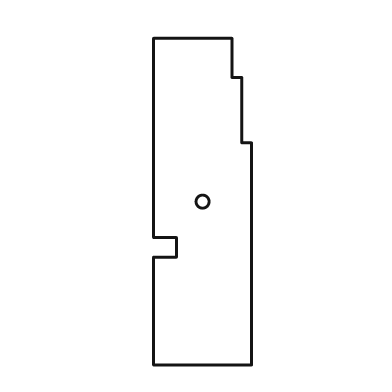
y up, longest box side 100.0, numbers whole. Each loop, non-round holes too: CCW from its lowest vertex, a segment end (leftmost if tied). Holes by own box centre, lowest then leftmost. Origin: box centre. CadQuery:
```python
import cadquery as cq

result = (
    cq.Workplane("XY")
    .moveTo(-15.0, -50.0)
    .lineTo(15.0, -50.0)
    .lineTo(15.0, 18.0)
    .lineTo(12.0, 18.0)
    .lineTo(12.0, 38.0)
    .lineTo(9.0, 38.0)
    .lineTo(9.0, 50.0)
    .lineTo(-15.0, 50.0)
    .lineTo(-15.0, -11.0)
    .lineTo(-8.0, -11.0)
    .lineTo(-8.0, -17.0)
    .lineTo(-15.0, -17.0)
    .close()
    .moveTo(0.0, 0.0)
    .circle(2.0)
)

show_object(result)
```